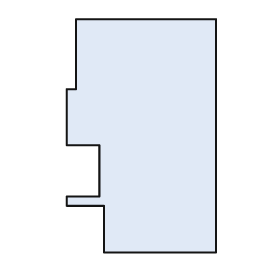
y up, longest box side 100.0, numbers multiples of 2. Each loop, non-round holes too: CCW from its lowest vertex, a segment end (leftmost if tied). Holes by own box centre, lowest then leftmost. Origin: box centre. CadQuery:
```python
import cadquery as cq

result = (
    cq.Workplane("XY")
    .moveTo(-16.0, -50.0)
    .lineTo(32.0, -50.0)
    .lineTo(32.0, 50.0)
    .lineTo(-28.0, 50.0)
    .lineTo(-28.0, 20.0)
    .lineTo(-32.0, 20.0)
    .lineTo(-32.0, -4.0)
    .lineTo(-18.0, -4.0)
    .lineTo(-18.0, -26.0)
    .lineTo(-32.0, -26.0)
    .lineTo(-32.0, -30.0)
    .lineTo(-16.0, -30.0)
    .close()
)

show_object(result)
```